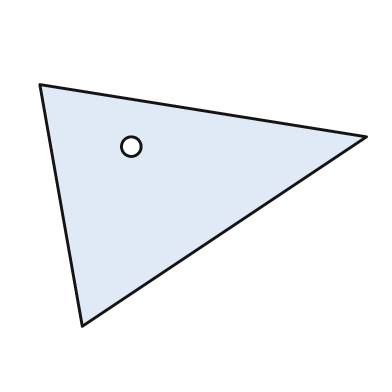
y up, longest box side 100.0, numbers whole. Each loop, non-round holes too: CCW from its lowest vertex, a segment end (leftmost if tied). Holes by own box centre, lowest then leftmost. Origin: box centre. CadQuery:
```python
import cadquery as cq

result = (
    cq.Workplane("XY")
    .moveTo(-37.0, -37.0)
    .lineTo(50.0, 21.0)
    .lineTo(-50.0, 37.0)
    .close()
    .moveTo(-22.0, 18.0)
    .circle(3.0)
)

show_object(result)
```